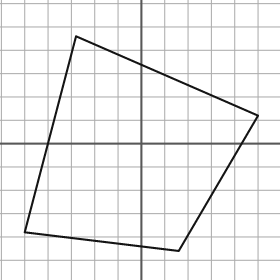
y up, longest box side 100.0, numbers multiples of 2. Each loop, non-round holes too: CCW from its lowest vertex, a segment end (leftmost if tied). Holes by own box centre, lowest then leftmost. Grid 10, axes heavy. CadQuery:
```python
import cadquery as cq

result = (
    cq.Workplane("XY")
    .moveTo(16.0, -46.0)
    .lineTo(50.0, 12.0)
    .lineTo(-28.0, 46.0)
    .lineTo(-50.0, -38.0)
    .close()
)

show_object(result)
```